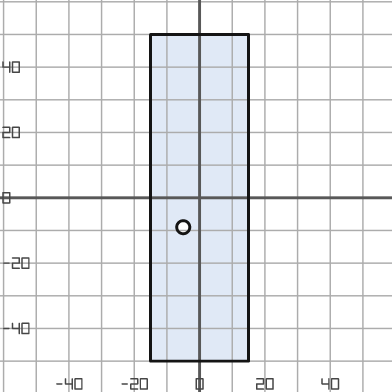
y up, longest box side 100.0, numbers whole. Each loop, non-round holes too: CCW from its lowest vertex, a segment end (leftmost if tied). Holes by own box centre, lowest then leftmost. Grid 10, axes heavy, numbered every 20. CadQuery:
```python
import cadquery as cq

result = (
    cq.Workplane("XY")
    .moveTo(-15.0, -50.0)
    .lineTo(15.0, -50.0)
    .lineTo(15.0, 50.0)
    .lineTo(-15.0, 50.0)
    .close()
    .moveTo(-5.0, -9.0)
    .circle(2.0)
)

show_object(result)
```